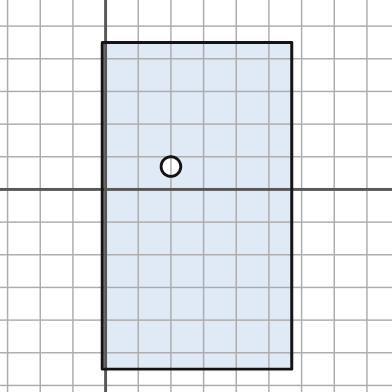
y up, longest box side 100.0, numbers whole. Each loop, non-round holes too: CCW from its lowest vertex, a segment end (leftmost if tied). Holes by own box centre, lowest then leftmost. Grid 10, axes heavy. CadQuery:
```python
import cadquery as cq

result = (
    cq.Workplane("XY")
    .moveTo(-1.0, -55.0)
    .lineTo(57.0, -55.0)
    .lineTo(57.0, 45.0)
    .lineTo(-1.0, 45.0)
    .close()
    .moveTo(20.0, 7.0)
    .circle(3.0)
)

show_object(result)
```